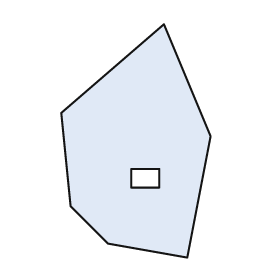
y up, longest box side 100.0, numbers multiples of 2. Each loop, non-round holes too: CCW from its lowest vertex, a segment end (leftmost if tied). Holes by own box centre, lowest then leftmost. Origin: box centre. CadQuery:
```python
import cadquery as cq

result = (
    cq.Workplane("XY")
    .moveTo(22.0, -50.0)
    .lineTo(32.0, 2.0)
    .lineTo(12.0, 50.0)
    .lineTo(-32.0, 12.0)
    .lineTo(-28.0, -28.0)
    .lineTo(-12.0, -44.0)
    .close()
    .moveTo(-2.0, -20.0)
    .lineTo(10.0, -20.0)
    .lineTo(10.0, -12.0)
    .lineTo(-2.0, -12.0)
    .close()
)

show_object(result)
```